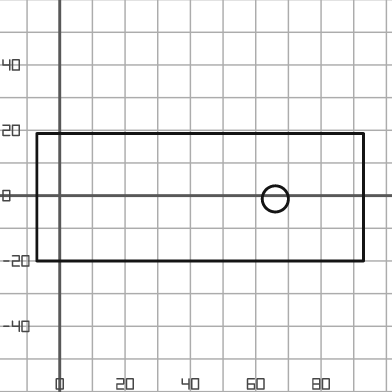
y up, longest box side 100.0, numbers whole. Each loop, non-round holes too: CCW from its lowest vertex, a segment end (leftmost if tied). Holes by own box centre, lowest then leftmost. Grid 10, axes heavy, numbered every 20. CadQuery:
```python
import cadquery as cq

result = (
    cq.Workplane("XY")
    .moveTo(-7.0, -20.0)
    .lineTo(93.0, -20.0)
    .lineTo(93.0, 19.0)
    .lineTo(-7.0, 19.0)
    .close()
    .moveTo(66.0, -1.0)
    .circle(4.0)
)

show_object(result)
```